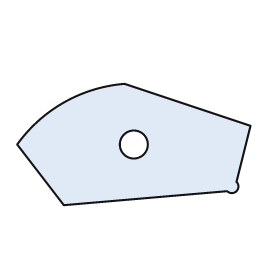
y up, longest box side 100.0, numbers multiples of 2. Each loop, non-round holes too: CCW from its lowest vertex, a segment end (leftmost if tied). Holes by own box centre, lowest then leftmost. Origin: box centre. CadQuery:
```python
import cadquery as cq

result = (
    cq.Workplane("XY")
    .moveTo(-30.0, -26.0)
    .lineTo(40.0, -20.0)
    .threePointArc((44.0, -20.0), (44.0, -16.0))
    .lineTo(50.0, 8.0)
    .lineTo(-4.0, 26.0)
    .threePointArc((-30.0, 18.0), (-50.0, 0.0))
    .close()
    .moveTo(0.0, 0.0)
    .circle(6.0)
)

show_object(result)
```